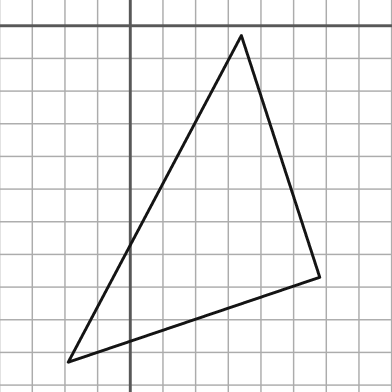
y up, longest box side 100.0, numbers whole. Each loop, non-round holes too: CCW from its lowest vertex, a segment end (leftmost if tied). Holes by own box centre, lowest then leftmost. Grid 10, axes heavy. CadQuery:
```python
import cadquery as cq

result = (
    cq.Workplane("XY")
    .moveTo(-19.0, -103.0)
    .lineTo(58.0, -77.0)
    .lineTo(34.0, -3.0)
    .close()
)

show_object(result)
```